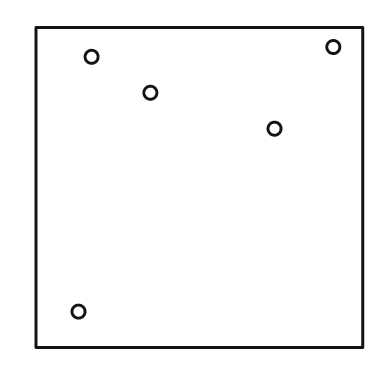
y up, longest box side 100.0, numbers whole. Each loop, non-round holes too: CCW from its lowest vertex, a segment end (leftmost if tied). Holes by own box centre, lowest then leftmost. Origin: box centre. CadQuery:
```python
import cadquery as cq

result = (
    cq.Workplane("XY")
    .moveTo(-50.0, -49.0)
    .lineTo(50.0, -49.0)
    .lineTo(50.0, 49.0)
    .lineTo(-50.0, 49.0)
    .close()
    .moveTo(-37.0, -38.0)
    .circle(2.0)
    .moveTo(23.0, 18.0)
    .circle(2.0)
    .moveTo(-15.0, 29.0)
    .circle(2.0)
    .moveTo(-33.0, 40.0)
    .circle(2.0)
    .moveTo(41.0, 43.0)
    .circle(2.0)
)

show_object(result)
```